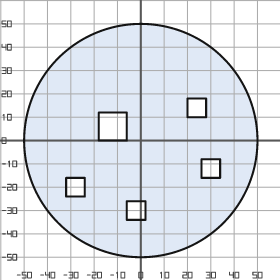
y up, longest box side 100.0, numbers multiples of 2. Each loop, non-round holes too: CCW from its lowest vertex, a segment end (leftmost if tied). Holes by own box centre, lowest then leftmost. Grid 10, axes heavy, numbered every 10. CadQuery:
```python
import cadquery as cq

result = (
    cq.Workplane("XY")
    .moveTo(0.0, 0.0)
    .circle(50.0)
    .moveTo(-6.0, -34.0)
    .lineTo(2.0, -34.0)
    .lineTo(2.0, -26.0)
    .lineTo(-6.0, -26.0)
    .close()
    .moveTo(-32.0, -24.0)
    .lineTo(-24.0, -24.0)
    .lineTo(-24.0, -16.0)
    .lineTo(-32.0, -16.0)
    .close()
    .moveTo(26.0, -16.0)
    .lineTo(34.0, -16.0)
    .lineTo(34.0, -8.0)
    .lineTo(26.0, -8.0)
    .close()
    .moveTo(-18.0, 0.0)
    .lineTo(-6.0, 0.0)
    .lineTo(-6.0, 12.0)
    .lineTo(-18.0, 12.0)
    .close()
    .moveTo(20.0, 10.0)
    .lineTo(28.0, 10.0)
    .lineTo(28.0, 18.0)
    .lineTo(20.0, 18.0)
    .close()
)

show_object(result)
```